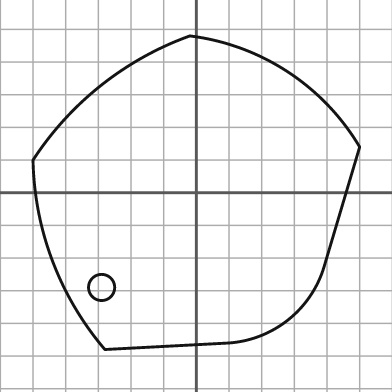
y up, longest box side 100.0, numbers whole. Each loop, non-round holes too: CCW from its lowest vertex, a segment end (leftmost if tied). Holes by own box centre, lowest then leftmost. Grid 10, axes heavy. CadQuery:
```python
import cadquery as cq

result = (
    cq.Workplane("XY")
    .moveTo(-28.0, -48.0)
    .lineTo(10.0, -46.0)
    .threePointArc((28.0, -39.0), (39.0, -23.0))
    .lineTo(50.0, 14.0)
    .threePointArc((28.0, 37.0), (-2.0, 48.0))
    .threePointArc((-29.0, 33.0), (-50.0, 10.0))
    .threePointArc((-44.0, -21.0), (-28.0, -48.0))
    .close()
    .moveTo(-29.0, -29.0)
    .circle(4.0)
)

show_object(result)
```